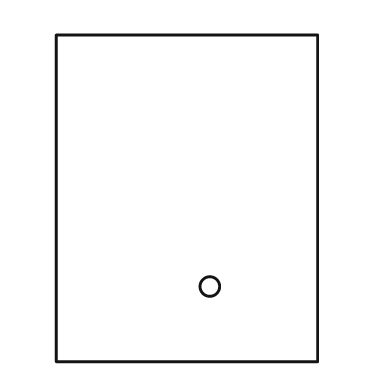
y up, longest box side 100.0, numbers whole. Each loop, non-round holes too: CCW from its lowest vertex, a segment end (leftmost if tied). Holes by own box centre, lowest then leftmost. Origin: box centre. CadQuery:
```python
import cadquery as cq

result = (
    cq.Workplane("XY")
    .moveTo(-40.0, -50.0)
    .lineTo(40.0, -50.0)
    .lineTo(40.0, 50.0)
    .lineTo(-40.0, 50.0)
    .close()
    .moveTo(7.0, -27.0)
    .circle(3.0)
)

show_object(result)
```